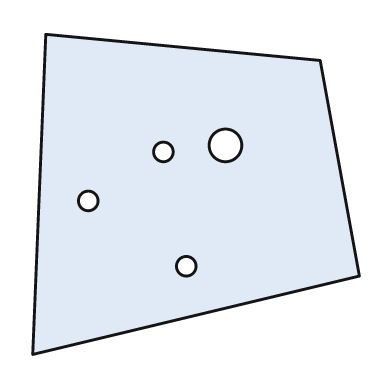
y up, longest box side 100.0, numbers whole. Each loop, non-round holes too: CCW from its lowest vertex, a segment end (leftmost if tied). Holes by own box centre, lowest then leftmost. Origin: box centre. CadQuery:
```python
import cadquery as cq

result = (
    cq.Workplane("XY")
    .moveTo(-50.0, -49.0)
    .lineTo(50.0, -25.0)
    .lineTo(38.0, 41.0)
    .lineTo(-46.0, 49.0)
    .close()
    .moveTo(-3.0, -22.0)
    .circle(3.0)
    .moveTo(-33.0, -2.0)
    .circle(3.0)
    .moveTo(-10.0, 13.0)
    .circle(3.0)
    .moveTo(9.0, 15.0)
    .circle(5.0)
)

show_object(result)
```